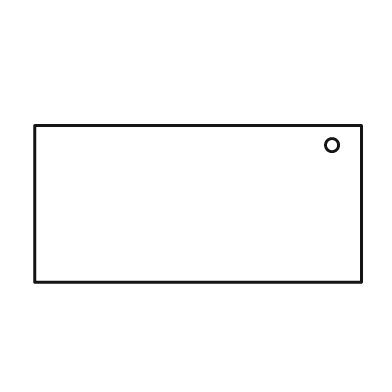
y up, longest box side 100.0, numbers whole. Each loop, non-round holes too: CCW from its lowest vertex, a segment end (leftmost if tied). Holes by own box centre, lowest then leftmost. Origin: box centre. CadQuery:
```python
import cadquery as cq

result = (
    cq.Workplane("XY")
    .moveTo(-50.0, -24.0)
    .lineTo(50.0, -24.0)
    .lineTo(50.0, 24.0)
    .lineTo(-50.0, 24.0)
    .close()
    .moveTo(41.0, 18.0)
    .circle(2.0)
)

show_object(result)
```